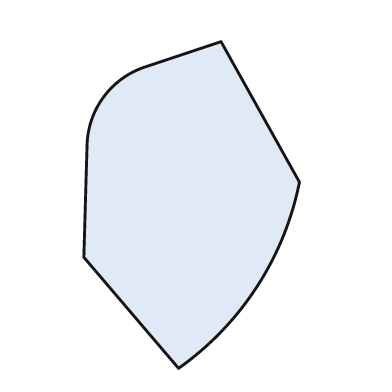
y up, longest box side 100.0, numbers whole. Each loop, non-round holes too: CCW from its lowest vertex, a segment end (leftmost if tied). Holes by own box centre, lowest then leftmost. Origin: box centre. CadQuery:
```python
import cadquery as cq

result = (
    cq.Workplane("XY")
    .moveTo(-4.0, -50.0)
    .threePointArc((20.0, -25.0), (33.0, 7.0))
    .lineTo(9.0, 50.0)
    .lineTo(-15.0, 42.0)
    .threePointArc((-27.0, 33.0), (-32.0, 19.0))
    .lineTo(-33.0, -16.0)
    .close()
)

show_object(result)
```